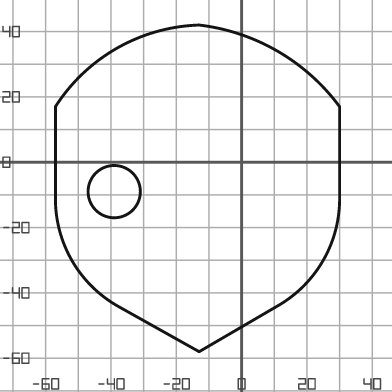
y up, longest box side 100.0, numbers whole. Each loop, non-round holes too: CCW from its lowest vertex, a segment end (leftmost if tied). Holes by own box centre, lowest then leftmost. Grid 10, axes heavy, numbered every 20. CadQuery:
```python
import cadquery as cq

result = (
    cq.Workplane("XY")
    .moveTo(-13.0, -58.0)
    .lineTo(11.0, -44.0)
    .threePointArc((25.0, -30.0), (30.0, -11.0))
    .lineTo(30.0, 17.0)
    .threePointArc((11.0, 34.0), (-13.0, 42.0))
    .threePointArc((-38.0, 35.0), (-57.0, 17.0))
    .lineTo(-57.0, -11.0)
    .threePointArc((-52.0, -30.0), (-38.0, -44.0))
    .close()
    .moveTo(-39.0, -9.0)
    .circle(8.0)
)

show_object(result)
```